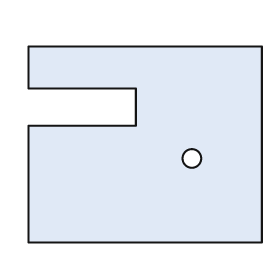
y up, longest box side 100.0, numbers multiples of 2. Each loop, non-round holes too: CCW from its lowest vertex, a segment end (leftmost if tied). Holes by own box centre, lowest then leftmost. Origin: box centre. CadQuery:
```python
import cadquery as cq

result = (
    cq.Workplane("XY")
    .moveTo(-50.0, -42.0)
    .lineTo(50.0, -42.0)
    .lineTo(50.0, 42.0)
    .lineTo(-50.0, 42.0)
    .lineTo(-50.0, 24.0)
    .lineTo(-4.0, 24.0)
    .lineTo(-4.0, 8.0)
    .lineTo(-50.0, 8.0)
    .close()
    .moveTo(20.0, -6.0)
    .circle(4.0)
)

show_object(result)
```